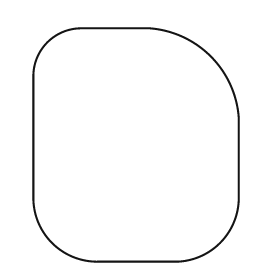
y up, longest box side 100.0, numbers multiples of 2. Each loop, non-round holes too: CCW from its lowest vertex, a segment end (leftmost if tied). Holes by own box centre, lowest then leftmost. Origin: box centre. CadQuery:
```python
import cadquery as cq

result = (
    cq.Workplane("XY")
    .moveTo(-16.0, -50.0)
    .lineTo(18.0, -50.0)
    .threePointArc((36.0, -42.0), (44.0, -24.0))
    .lineTo(44.0, 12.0)
    .threePointArc((32.0, 38.0), (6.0, 50.0))
    .lineTo(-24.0, 50.0)
    .threePointArc((-38.0, 44.0), (-44.0, 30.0))
    .lineTo(-44.0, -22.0)
    .threePointArc((-36.0, -42.0), (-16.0, -50.0))
    .close()
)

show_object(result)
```